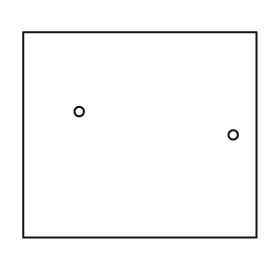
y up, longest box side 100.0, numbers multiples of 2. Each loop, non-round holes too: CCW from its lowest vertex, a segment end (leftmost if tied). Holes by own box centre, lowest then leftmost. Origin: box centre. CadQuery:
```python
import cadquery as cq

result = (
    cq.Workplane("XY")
    .moveTo(-50.0, -44.0)
    .lineTo(50.0, -44.0)
    .lineTo(50.0, 44.0)
    .lineTo(-50.0, 44.0)
    .close()
    .moveTo(40.0, 0.0)
    .circle(2.0)
    .moveTo(-26.0, 10.0)
    .circle(2.0)
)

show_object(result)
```